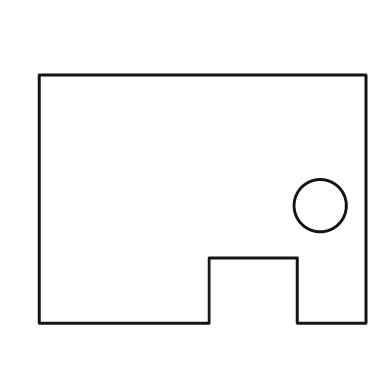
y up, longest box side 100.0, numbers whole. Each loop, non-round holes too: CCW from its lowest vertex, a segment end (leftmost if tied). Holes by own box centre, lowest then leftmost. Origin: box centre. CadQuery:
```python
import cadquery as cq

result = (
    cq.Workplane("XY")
    .moveTo(-50.0, -38.0)
    .lineTo(2.0, -38.0)
    .lineTo(2.0, -18.0)
    .lineTo(29.0, -18.0)
    .lineTo(29.0, -38.0)
    .lineTo(50.0, -38.0)
    .lineTo(50.0, 38.0)
    .lineTo(-50.0, 38.0)
    .close()
    .moveTo(36.0, -2.0)
    .circle(8.0)
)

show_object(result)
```